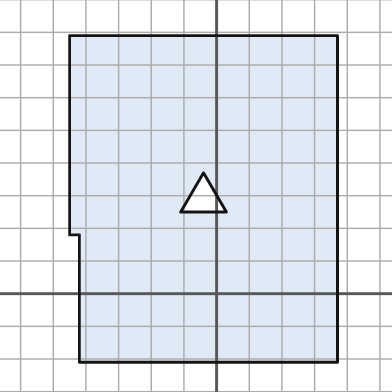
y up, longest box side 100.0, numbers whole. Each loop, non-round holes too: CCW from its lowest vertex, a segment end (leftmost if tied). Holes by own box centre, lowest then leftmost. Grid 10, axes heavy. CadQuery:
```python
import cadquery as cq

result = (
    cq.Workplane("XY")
    .moveTo(-42.0, -21.0)
    .lineTo(37.0, -21.0)
    .lineTo(37.0, 79.0)
    .lineTo(-45.0, 79.0)
    .lineTo(-45.0, 18.0)
    .lineTo(-42.0, 18.0)
    .close()
    .moveTo(-11.0, 25.0)
    .lineTo(3.0, 25.0)
    .lineTo(-4.0, 37.0)
    .close()
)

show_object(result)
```